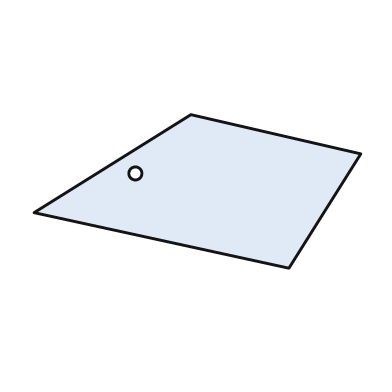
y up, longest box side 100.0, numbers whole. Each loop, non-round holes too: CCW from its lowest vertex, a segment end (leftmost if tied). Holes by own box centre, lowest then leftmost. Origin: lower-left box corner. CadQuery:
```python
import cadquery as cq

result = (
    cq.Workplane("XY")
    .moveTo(78.0, 0.0)
    .lineTo(100.0, 35.0)
    .lineTo(48.0, 47.0)
    .lineTo(0.0, 17.0)
    .close()
    .moveTo(31.0, 29.0)
    .circle(2.0)
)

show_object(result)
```